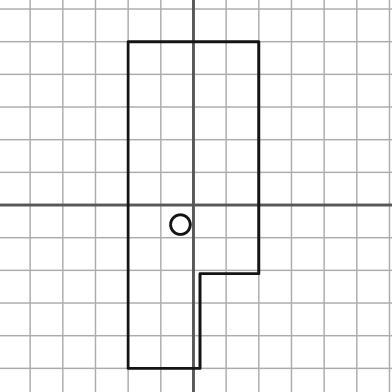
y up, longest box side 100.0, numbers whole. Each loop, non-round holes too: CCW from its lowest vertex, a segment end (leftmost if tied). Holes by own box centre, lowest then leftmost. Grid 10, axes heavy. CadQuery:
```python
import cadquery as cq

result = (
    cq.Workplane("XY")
    .moveTo(-20.0, -50.0)
    .lineTo(2.0, -50.0)
    .lineTo(2.0, -21.0)
    .lineTo(20.0, -21.0)
    .lineTo(20.0, 50.0)
    .lineTo(-20.0, 50.0)
    .close()
    .moveTo(-4.0, -6.0)
    .circle(3.0)
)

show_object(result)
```